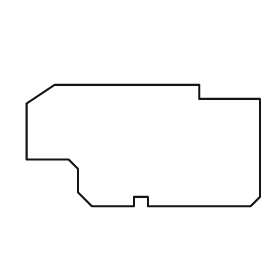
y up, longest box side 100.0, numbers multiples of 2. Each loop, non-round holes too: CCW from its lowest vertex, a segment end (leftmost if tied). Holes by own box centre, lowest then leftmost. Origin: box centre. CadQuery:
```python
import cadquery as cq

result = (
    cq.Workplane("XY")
    .moveTo(-22.0, -26.0)
    .lineTo(-4.0, -26.0)
    .lineTo(-4.0, -22.0)
    .lineTo(2.0, -22.0)
    .lineTo(2.0, -26.0)
    .lineTo(46.0, -26.0)
    .lineTo(50.0, -22.0)
    .lineTo(50.0, 20.0)
    .lineTo(24.0, 20.0)
    .lineTo(24.0, 26.0)
    .lineTo(-38.0, 26.0)
    .lineTo(-50.0, 18.0)
    .lineTo(-50.0, -6.0)
    .lineTo(-32.0, -6.0)
    .lineTo(-28.0, -10.0)
    .lineTo(-28.0, -20.0)
    .close()
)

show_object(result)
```